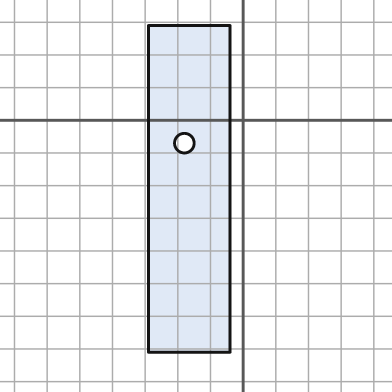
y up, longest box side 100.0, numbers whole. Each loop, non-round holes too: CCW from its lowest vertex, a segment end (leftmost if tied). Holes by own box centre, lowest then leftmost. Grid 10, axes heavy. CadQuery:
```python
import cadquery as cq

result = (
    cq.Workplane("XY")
    .moveTo(-29.0, -71.0)
    .lineTo(-4.0, -71.0)
    .lineTo(-4.0, 29.0)
    .lineTo(-29.0, 29.0)
    .close()
    .moveTo(-18.0, -7.0)
    .circle(3.0)
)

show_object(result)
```